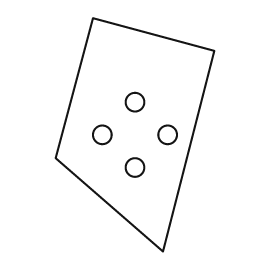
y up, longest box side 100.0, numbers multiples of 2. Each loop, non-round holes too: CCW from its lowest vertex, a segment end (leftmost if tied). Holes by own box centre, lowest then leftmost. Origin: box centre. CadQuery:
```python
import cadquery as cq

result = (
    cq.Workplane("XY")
    .moveTo(12.0, -50.0)
    .lineTo(34.0, 36.0)
    .lineTo(-18.0, 50.0)
    .lineTo(-34.0, -10.0)
    .close()
    .moveTo(0.0, -14.0)
    .circle(4.0)
    .moveTo(-14.0, 0.0)
    .circle(4.0)
    .moveTo(14.0, 0.0)
    .circle(4.0)
    .moveTo(0.0, 14.0)
    .circle(4.0)
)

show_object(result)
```